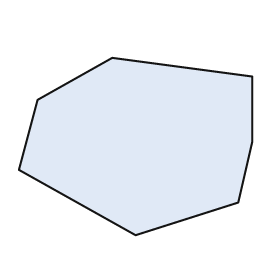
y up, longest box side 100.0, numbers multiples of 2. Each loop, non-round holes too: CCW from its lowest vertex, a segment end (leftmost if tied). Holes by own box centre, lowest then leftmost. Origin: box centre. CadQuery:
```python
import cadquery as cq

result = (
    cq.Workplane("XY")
    .moveTo(0.0, -38.0)
    .lineTo(44.0, -24.0)
    .lineTo(50.0, 2.0)
    .lineTo(50.0, 30.0)
    .lineTo(-10.0, 38.0)
    .lineTo(-42.0, 20.0)
    .lineTo(-50.0, -10.0)
    .close()
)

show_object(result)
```